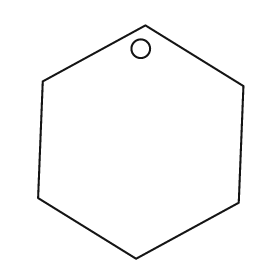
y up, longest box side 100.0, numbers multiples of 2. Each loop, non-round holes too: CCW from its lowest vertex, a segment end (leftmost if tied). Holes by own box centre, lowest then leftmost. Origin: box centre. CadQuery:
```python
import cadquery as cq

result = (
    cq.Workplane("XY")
    .moveTo(-2.0, -50.0)
    .lineTo(42.0, -26.0)
    .lineTo(44.0, 24.0)
    .lineTo(2.0, 50.0)
    .lineTo(-42.0, 26.0)
    .lineTo(-44.0, -24.0)
    .close()
    .moveTo(0.0, 40.0)
    .circle(4.0)
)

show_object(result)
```